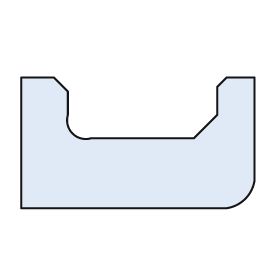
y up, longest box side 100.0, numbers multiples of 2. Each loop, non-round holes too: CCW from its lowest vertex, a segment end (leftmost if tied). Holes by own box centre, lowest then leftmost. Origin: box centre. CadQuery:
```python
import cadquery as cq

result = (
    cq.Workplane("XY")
    .moveTo(-50.0, -28.0)
    .lineTo(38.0, -28.0)
    .threePointArc((46.0, -24.0), (50.0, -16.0))
    .lineTo(50.0, 28.0)
    .lineTo(38.0, 28.0)
    .lineTo(34.0, 24.0)
    .lineTo(34.0, 12.0)
    .lineTo(24.0, 2.0)
    .lineTo(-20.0, 2.0)
    .threePointArc((-28.0, 4.0), (-30.0, 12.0))
    .lineTo(-30.0, 22.0)
    .lineTo(-36.0, 28.0)
    .lineTo(-50.0, 28.0)
    .close()
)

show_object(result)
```